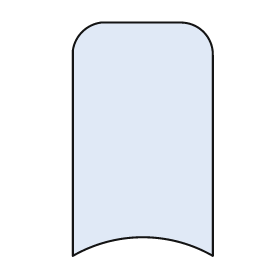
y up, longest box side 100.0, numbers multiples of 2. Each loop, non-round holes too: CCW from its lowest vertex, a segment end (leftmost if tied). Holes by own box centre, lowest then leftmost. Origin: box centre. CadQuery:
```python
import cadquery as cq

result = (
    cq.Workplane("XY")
    .moveTo(-30.0, -50.0)
    .threePointArc((0.0, -42.0), (30.0, -50.0))
    .lineTo(30.0, 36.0)
    .threePointArc((26.0, 46.0), (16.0, 50.0))
    .lineTo(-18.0, 50.0)
    .threePointArc((-26.0, 46.0), (-30.0, 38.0))
    .close()
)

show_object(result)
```